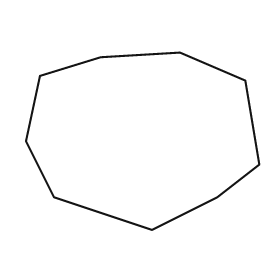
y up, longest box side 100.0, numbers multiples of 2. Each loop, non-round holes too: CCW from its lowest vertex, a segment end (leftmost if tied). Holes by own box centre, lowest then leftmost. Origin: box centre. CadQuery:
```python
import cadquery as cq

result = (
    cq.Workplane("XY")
    .moveTo(4.0, -38.0)
    .lineTo(32.0, -24.0)
    .lineTo(50.0, -10.0)
    .lineTo(44.0, 26.0)
    .lineTo(16.0, 38.0)
    .lineTo(-18.0, 36.0)
    .lineTo(-44.0, 28.0)
    .lineTo(-50.0, 0.0)
    .lineTo(-38.0, -24.0)
    .close()
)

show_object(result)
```